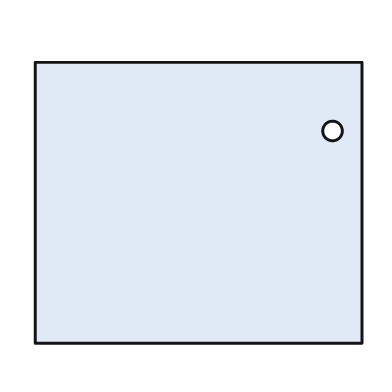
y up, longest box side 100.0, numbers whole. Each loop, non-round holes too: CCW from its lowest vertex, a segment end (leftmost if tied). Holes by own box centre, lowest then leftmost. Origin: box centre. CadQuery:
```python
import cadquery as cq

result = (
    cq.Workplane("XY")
    .moveTo(-50.0, -43.0)
    .lineTo(50.0, -43.0)
    .lineTo(50.0, 43.0)
    .lineTo(-50.0, 43.0)
    .close()
    .moveTo(41.0, 22.0)
    .circle(3.0)
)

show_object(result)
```